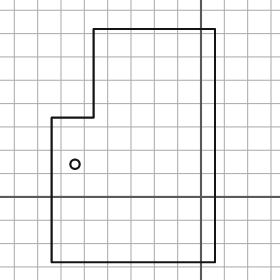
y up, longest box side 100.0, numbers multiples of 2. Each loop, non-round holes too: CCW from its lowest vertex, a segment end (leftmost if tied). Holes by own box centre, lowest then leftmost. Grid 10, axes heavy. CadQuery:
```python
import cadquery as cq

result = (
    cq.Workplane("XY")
    .moveTo(-64.0, -28.0)
    .lineTo(6.0, -28.0)
    .lineTo(6.0, 72.0)
    .lineTo(-46.0, 72.0)
    .lineTo(-46.0, 34.0)
    .lineTo(-64.0, 34.0)
    .close()
    .moveTo(-54.0, 14.0)
    .circle(2.0)
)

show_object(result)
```